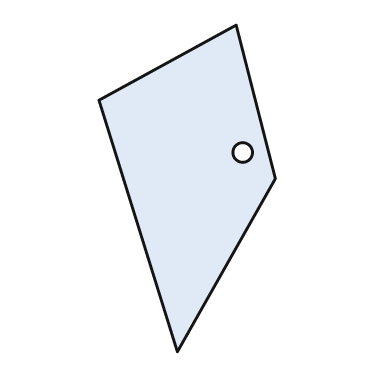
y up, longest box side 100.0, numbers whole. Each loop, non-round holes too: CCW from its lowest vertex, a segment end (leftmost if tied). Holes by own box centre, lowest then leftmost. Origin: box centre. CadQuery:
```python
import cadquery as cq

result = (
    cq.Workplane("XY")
    .moveTo(-3.0, -50.0)
    .lineTo(27.0, 3.0)
    .lineTo(15.0, 50.0)
    .lineTo(-27.0, 27.0)
    .close()
    .moveTo(17.0, 11.0)
    .circle(3.0)
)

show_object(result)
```